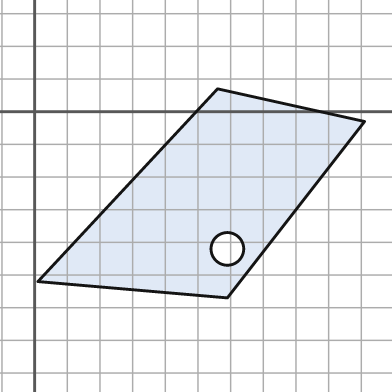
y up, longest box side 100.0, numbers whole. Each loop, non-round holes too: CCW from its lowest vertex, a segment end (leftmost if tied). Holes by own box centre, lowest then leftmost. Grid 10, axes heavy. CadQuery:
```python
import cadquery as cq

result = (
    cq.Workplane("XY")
    .moveTo(59.0, -57.0)
    .lineTo(101.0, -3.0)
    .lineTo(56.0, 7.0)
    .lineTo(1.0, -52.0)
    .close()
    .moveTo(59.0, -42.0)
    .circle(5.0)
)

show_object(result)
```